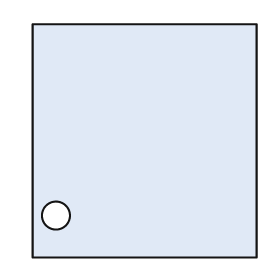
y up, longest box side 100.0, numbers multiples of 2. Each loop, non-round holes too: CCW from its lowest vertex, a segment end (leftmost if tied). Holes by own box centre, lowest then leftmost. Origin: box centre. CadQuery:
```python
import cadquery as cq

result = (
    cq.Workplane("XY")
    .moveTo(-48.0, -50.0)
    .lineTo(48.0, -50.0)
    .lineTo(48.0, 50.0)
    .lineTo(-48.0, 50.0)
    .close()
    .moveTo(-38.0, -32.0)
    .circle(6.0)
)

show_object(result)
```